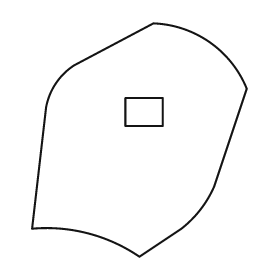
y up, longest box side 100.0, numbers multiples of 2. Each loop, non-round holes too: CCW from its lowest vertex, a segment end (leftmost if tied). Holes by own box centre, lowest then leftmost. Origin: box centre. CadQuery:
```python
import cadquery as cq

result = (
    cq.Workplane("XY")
    .moveTo(0.0, -50.0)
    .lineTo(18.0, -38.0)
    .threePointArc((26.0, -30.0), (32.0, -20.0))
    .lineTo(46.0, 22.0)
    .threePointArc((30.0, 42.0), (6.0, 50.0))
    .lineTo(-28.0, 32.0)
    .threePointArc((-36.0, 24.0), (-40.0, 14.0))
    .lineTo(-46.0, -38.0)
    .threePointArc((-22.0, -40.0), (0.0, -50.0))
    .close()
    .moveTo(-6.0, 6.0)
    .lineTo(10.0, 6.0)
    .lineTo(10.0, 18.0)
    .lineTo(-6.0, 18.0)
    .close()
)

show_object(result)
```